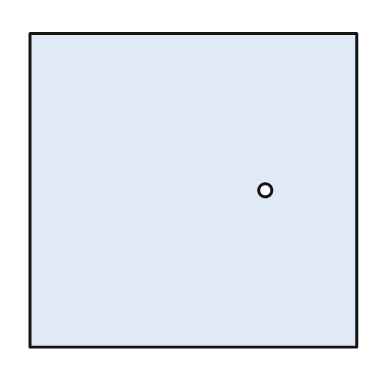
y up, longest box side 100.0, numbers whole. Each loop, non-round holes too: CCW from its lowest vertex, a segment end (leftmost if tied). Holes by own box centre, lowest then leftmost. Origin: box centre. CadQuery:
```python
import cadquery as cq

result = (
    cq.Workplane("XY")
    .moveTo(-50.0, -48.0)
    .lineTo(50.0, -48.0)
    .lineTo(50.0, 48.0)
    .lineTo(-50.0, 48.0)
    .close()
    .moveTo(22.0, 0.0)
    .circle(2.0)
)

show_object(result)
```